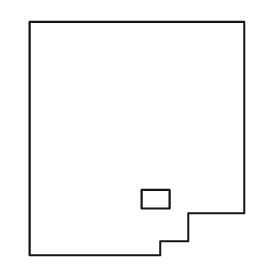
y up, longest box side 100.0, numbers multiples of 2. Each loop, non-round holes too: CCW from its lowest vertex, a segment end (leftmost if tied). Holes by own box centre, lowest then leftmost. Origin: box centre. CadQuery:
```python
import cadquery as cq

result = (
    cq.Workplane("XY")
    .moveTo(-46.0, -50.0)
    .lineTo(10.0, -50.0)
    .lineTo(10.0, -44.0)
    .lineTo(22.0, -44.0)
    .lineTo(22.0, -32.0)
    .lineTo(46.0, -32.0)
    .lineTo(46.0, 50.0)
    .lineTo(-46.0, 50.0)
    .close()
    .moveTo(2.0, -30.0)
    .lineTo(14.0, -30.0)
    .lineTo(14.0, -22.0)
    .lineTo(2.0, -22.0)
    .close()
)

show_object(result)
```